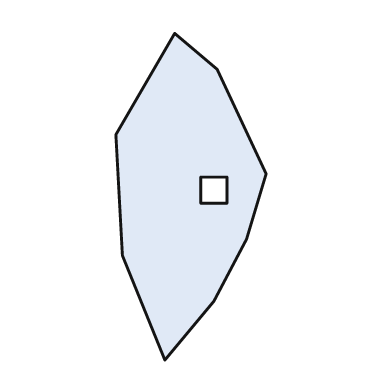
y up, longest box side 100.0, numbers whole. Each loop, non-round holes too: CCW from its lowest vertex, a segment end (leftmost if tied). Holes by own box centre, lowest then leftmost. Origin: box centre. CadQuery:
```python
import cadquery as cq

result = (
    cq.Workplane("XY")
    .moveTo(-8.0, -50.0)
    .lineTo(7.0, -32.0)
    .lineTo(17.0, -13.0)
    .lineTo(23.0, 7.0)
    .lineTo(8.0, 39.0)
    .lineTo(-5.0, 50.0)
    .lineTo(-23.0, 19.0)
    .lineTo(-21.0, -18.0)
    .close()
    .moveTo(3.0, -2.0)
    .lineTo(11.0, -2.0)
    .lineTo(11.0, 6.0)
    .lineTo(3.0, 6.0)
    .close()
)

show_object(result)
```